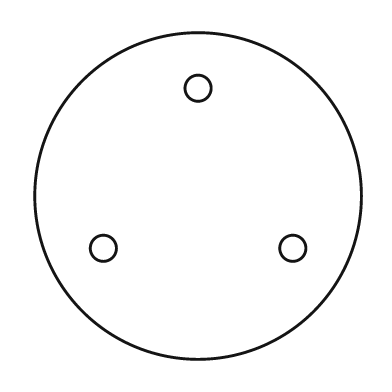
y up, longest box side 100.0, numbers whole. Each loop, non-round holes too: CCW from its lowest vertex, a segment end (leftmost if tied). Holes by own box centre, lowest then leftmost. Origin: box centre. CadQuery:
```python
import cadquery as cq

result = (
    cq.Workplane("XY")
    .moveTo(0.0, 0.0)
    .circle(50.0)
    .moveTo(-29.0, -16.0)
    .circle(4.0)
    .moveTo(29.0, -16.0)
    .circle(4.0)
    .moveTo(0.0, 33.0)
    .circle(4.0)
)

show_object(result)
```